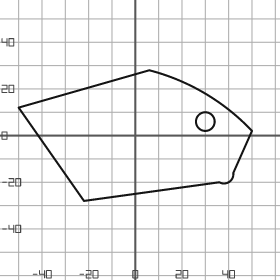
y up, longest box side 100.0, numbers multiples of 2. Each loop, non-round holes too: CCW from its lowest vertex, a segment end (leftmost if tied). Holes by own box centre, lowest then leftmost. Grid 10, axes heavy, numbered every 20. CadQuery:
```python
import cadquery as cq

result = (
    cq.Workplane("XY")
    .moveTo(-22.0, -28.0)
    .lineTo(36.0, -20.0)
    .threePointArc((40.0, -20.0), (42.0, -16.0))
    .lineTo(50.0, 2.0)
    .threePointArc((30.0, 18.0), (6.0, 28.0))
    .lineTo(-50.0, 12.0)
    .close()
    .moveTo(30.0, 6.0)
    .circle(4.0)
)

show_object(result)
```